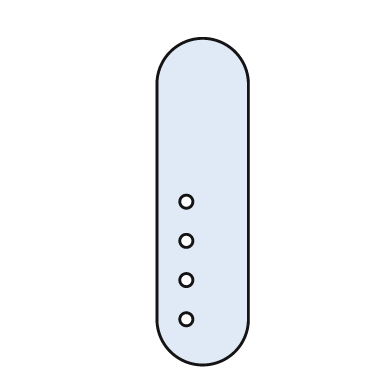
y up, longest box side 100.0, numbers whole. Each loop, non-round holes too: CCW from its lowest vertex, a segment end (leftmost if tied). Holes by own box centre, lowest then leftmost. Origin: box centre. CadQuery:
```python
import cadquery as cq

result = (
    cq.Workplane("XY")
    .moveTo(-14.0, -36.0)
    .threePointArc((0.0, -50.0), (14.0, -36.0))
    .lineTo(14.0, 36.0)
    .threePointArc((0.0, 50.0), (-14.0, 36.0))
    .close()
    .moveTo(-5.0, -36.0)
    .circle(2.0)
    .moveTo(-5.0, -24.0)
    .circle(2.0)
    .moveTo(-5.0, -12.0)
    .circle(2.0)
    .moveTo(-5.0, 0.0)
    .circle(2.0)
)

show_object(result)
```